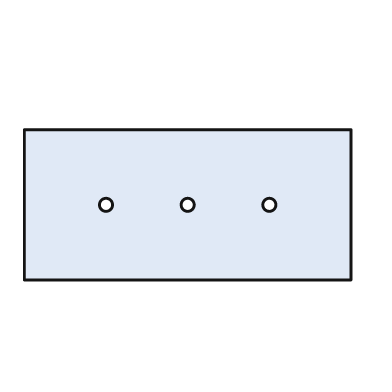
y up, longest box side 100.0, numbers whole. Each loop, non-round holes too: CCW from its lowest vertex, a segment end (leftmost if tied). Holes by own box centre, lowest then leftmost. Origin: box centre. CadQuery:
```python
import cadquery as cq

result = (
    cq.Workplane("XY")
    .moveTo(-50.0, -23.0)
    .lineTo(50.0, -23.0)
    .lineTo(50.0, 23.0)
    .lineTo(-50.0, 23.0)
    .close()
    .moveTo(-25.0, 0.0)
    .circle(2.0)
    .moveTo(0.0, 0.0)
    .circle(2.0)
    .moveTo(25.0, 0.0)
    .circle(2.0)
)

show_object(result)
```